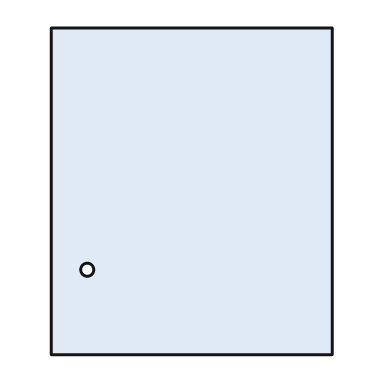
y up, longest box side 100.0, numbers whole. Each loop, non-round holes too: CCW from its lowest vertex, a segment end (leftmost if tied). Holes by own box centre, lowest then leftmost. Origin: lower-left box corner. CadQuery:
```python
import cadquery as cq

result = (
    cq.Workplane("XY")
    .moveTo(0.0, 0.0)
    .lineTo(86.0, 0.0)
    .lineTo(86.0, 100.0)
    .lineTo(0.0, 100.0)
    .close()
    .moveTo(11.0, 26.0)
    .circle(2.0)
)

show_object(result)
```